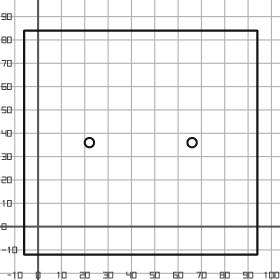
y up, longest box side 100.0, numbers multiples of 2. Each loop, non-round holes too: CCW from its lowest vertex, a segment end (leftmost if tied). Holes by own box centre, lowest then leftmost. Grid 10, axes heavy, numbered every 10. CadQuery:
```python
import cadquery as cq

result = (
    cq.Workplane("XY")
    .moveTo(-6.0, -12.0)
    .lineTo(94.0, -12.0)
    .lineTo(94.0, 84.0)
    .lineTo(-6.0, 84.0)
    .close()
    .moveTo(22.0, 36.0)
    .circle(2.0)
    .moveTo(66.0, 36.0)
    .circle(2.0)
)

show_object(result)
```